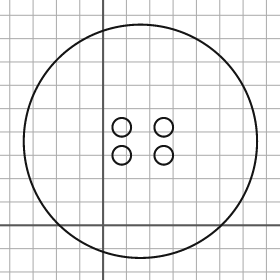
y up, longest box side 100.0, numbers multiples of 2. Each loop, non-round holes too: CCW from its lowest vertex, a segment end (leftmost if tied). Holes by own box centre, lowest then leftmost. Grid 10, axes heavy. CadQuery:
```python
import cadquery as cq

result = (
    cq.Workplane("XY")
    .moveTo(16.0, 36.0)
    .circle(50.0)
    .moveTo(8.0, 30.0)
    .circle(4.0)
    .moveTo(26.0, 30.0)
    .circle(4.0)
    .moveTo(8.0, 42.0)
    .circle(4.0)
    .moveTo(26.0, 42.0)
    .circle(4.0)
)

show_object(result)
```